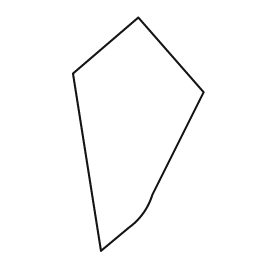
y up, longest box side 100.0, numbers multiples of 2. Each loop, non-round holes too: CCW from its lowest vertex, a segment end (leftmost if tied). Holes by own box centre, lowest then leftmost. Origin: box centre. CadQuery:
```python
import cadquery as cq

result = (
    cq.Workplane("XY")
    .moveTo(-16.0, -50.0)
    .lineTo(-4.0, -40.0)
    .threePointArc((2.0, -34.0), (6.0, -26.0))
    .lineTo(28.0, 18.0)
    .lineTo(0.0, 50.0)
    .lineTo(-28.0, 26.0)
    .close()
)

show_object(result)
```